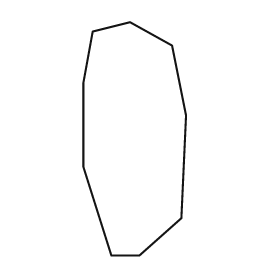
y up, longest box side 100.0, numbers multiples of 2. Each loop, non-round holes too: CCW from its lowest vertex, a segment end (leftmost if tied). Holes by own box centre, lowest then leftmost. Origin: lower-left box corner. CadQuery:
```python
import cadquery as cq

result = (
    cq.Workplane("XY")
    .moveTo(12.0, 0.0)
    .lineTo(24.0, 0.0)
    .lineTo(42.0, 16.0)
    .lineTo(44.0, 60.0)
    .lineTo(38.0, 90.0)
    .lineTo(20.0, 100.0)
    .lineTo(4.0, 96.0)
    .lineTo(0.0, 74.0)
    .lineTo(0.0, 38.0)
    .close()
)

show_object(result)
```